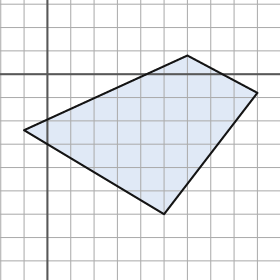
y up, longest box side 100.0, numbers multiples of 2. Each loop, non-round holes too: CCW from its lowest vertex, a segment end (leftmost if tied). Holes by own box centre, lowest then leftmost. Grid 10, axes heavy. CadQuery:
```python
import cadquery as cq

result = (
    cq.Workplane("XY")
    .moveTo(50.0, -60.0)
    .lineTo(90.0, -8.0)
    .lineTo(60.0, 8.0)
    .lineTo(-10.0, -24.0)
    .close()
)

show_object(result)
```